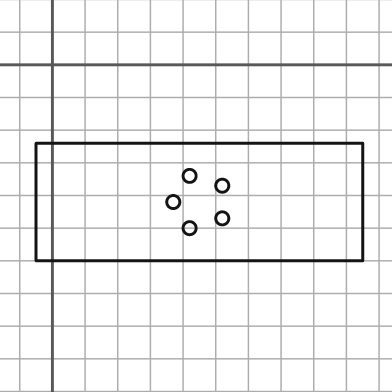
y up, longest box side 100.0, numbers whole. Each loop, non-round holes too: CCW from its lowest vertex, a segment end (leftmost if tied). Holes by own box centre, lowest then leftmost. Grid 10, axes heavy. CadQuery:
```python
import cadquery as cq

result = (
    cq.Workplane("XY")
    .moveTo(-5.0, -60.0)
    .lineTo(95.0, -60.0)
    .lineTo(95.0, -24.0)
    .lineTo(-5.0, -24.0)
    .close()
    .moveTo(42.0, -50.0)
    .circle(2.0)
    .moveTo(52.0, -47.0)
    .circle(2.0)
    .moveTo(37.0, -42.0)
    .circle(2.0)
    .moveTo(52.0, -37.0)
    .circle(2.0)
    .moveTo(42.0, -34.0)
    .circle(2.0)
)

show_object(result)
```